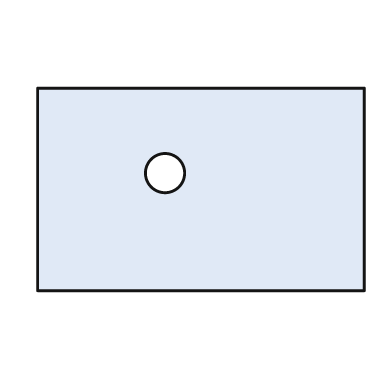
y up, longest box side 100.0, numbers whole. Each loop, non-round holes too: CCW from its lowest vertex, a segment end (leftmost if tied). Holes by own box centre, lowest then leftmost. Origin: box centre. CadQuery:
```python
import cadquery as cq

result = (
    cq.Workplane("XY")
    .moveTo(-50.0, -31.0)
    .lineTo(50.0, -31.0)
    .lineTo(50.0, 31.0)
    .lineTo(-50.0, 31.0)
    .close()
    .moveTo(-11.0, 5.0)
    .circle(6.0)
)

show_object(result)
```